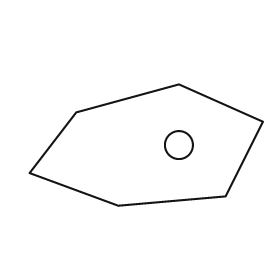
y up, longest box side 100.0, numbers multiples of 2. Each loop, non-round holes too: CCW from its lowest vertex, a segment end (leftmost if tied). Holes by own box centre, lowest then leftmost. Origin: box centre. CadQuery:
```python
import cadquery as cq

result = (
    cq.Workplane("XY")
    .moveTo(-12.0, -26.0)
    .lineTo(34.0, -22.0)
    .lineTo(50.0, 10.0)
    .lineTo(14.0, 26.0)
    .lineTo(-30.0, 14.0)
    .lineTo(-50.0, -12.0)
    .close()
    .moveTo(14.0, 0.0)
    .circle(6.0)
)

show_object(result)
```